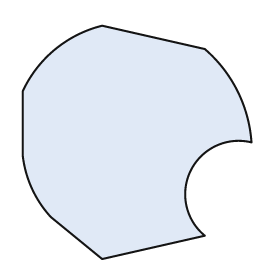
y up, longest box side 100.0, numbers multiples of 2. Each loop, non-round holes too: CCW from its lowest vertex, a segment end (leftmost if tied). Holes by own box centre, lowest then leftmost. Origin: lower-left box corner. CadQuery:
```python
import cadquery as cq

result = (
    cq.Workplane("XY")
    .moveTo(34.0, 0.0)
    .lineTo(78.0, 10.0)
    .threePointArc((72.0, 38.0), (98.0, 50.0))
    .threePointArc((92.0, 72.0), (78.0, 90.0))
    .lineTo(34.0, 100.0)
    .threePointArc((14.0, 90.0), (0.0, 72.0))
    .lineTo(0.0, 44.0)
    .threePointArc((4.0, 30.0), (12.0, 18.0))
    .close()
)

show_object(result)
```